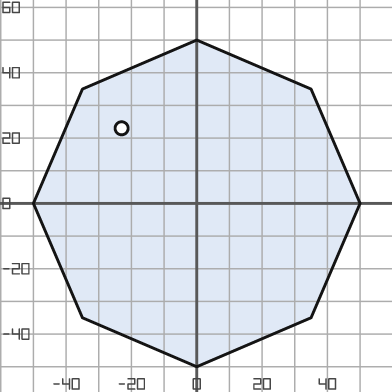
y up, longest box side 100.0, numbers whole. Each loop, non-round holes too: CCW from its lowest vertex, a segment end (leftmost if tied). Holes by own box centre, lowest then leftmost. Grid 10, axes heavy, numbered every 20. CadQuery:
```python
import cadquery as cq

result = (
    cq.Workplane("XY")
    .moveTo(0.0, -50.0)
    .lineTo(35.0, -35.0)
    .lineTo(50.0, 0.0)
    .lineTo(35.0, 35.0)
    .lineTo(0.0, 50.0)
    .lineTo(-35.0, 35.0)
    .lineTo(-50.0, 0.0)
    .lineTo(-35.0, -35.0)
    .close()
    .moveTo(-23.0, 23.0)
    .circle(2.0)
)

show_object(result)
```